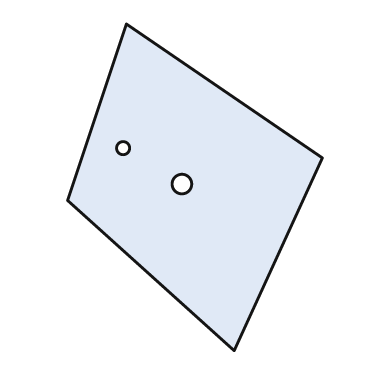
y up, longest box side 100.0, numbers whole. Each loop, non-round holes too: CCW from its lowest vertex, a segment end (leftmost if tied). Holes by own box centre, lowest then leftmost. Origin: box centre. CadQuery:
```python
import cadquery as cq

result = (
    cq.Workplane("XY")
    .moveTo(12.0, -50.0)
    .lineTo(39.0, 9.0)
    .lineTo(-21.0, 50.0)
    .lineTo(-39.0, -4.0)
    .close()
    .moveTo(-4.0, 1.0)
    .circle(3.0)
    .moveTo(-22.0, 12.0)
    .circle(2.0)
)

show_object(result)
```